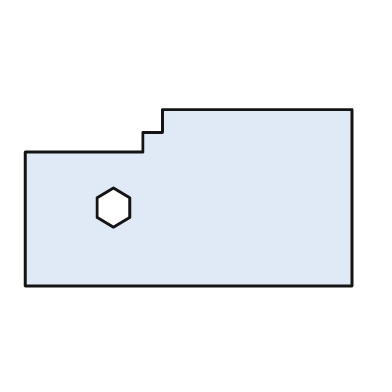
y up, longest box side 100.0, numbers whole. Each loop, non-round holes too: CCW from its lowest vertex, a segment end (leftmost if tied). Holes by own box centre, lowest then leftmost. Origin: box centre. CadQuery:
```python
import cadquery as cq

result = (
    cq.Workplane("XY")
    .moveTo(-50.0, -27.0)
    .lineTo(50.0, -27.0)
    .lineTo(50.0, 27.0)
    .lineTo(-8.0, 27.0)
    .lineTo(-8.0, 20.0)
    .lineTo(-14.0, 20.0)
    .lineTo(-14.0, 14.0)
    .lineTo(-50.0, 14.0)
    .close()
    .moveTo(-23.0, -9.0)
    .lineTo(-18.0, -6.0)
    .lineTo(-18.0, 0.0)
    .lineTo(-23.0, 3.0)
    .lineTo(-28.0, 0.0)
    .lineTo(-28.0, -6.0)
    .close()
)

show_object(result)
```